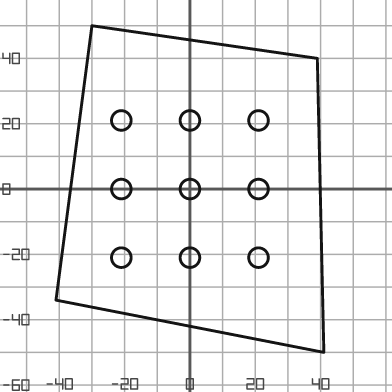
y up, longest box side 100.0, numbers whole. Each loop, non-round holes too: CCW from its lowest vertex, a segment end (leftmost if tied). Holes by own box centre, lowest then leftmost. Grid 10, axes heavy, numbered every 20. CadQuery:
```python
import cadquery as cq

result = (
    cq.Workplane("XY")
    .moveTo(41.0, -50.0)
    .lineTo(39.0, 40.0)
    .lineTo(-30.0, 50.0)
    .lineTo(-41.0, -34.0)
    .close()
    .moveTo(-21.0, -21.0)
    .circle(3.0)
    .moveTo(0.0, -21.0)
    .circle(3.0)
    .moveTo(21.0, -21.0)
    .circle(3.0)
    .moveTo(-21.0, 0.0)
    .circle(3.0)
    .moveTo(0.0, 0.0)
    .circle(3.0)
    .moveTo(21.0, 0.0)
    .circle(3.0)
    .moveTo(-21.0, 21.0)
    .circle(3.0)
    .moveTo(0.0, 21.0)
    .circle(3.0)
    .moveTo(21.0, 21.0)
    .circle(3.0)
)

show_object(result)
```